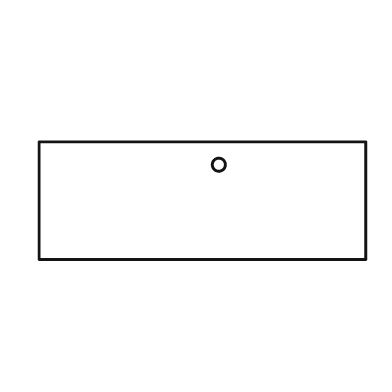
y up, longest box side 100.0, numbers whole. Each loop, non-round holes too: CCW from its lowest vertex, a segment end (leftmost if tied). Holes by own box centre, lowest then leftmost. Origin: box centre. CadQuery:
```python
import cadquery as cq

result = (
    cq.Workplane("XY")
    .moveTo(-50.0, -18.0)
    .lineTo(50.0, -18.0)
    .lineTo(50.0, 18.0)
    .lineTo(-50.0, 18.0)
    .close()
    .moveTo(5.0, 11.0)
    .circle(2.0)
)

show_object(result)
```